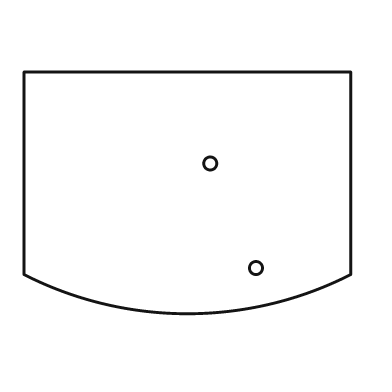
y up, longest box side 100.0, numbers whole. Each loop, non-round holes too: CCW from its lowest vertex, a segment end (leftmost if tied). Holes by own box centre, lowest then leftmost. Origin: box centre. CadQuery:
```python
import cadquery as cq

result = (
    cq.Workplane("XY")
    .moveTo(-50.0, -25.0)
    .threePointArc((0.0, -37.0), (50.0, -25.0))
    .lineTo(50.0, 37.0)
    .lineTo(-50.0, 37.0)
    .close()
    .moveTo(21.0, -23.0)
    .circle(2.0)
    .moveTo(7.0, 9.0)
    .circle(2.0)
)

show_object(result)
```